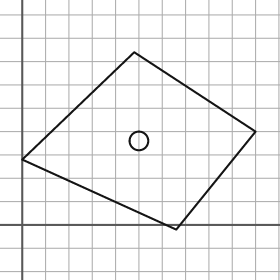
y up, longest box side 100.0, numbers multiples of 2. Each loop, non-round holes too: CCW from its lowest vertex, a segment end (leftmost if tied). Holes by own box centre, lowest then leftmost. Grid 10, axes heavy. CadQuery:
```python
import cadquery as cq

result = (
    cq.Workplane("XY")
    .moveTo(66.0, -2.0)
    .lineTo(100.0, 40.0)
    .lineTo(48.0, 74.0)
    .lineTo(0.0, 28.0)
    .close()
    .moveTo(50.0, 36.0)
    .circle(4.0)
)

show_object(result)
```